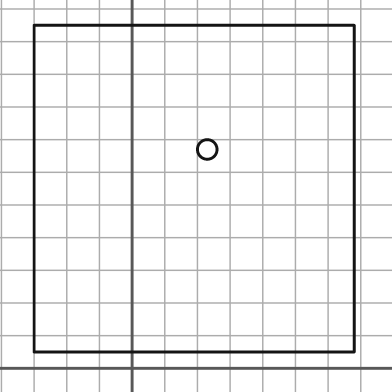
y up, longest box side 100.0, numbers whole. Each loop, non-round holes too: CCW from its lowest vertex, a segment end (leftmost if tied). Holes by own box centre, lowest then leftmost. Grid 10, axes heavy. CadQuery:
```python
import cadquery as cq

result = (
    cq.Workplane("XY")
    .moveTo(-30.0, 5.0)
    .lineTo(68.0, 5.0)
    .lineTo(68.0, 105.0)
    .lineTo(-30.0, 105.0)
    .close()
    .moveTo(23.0, 67.0)
    .circle(3.0)
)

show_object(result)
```